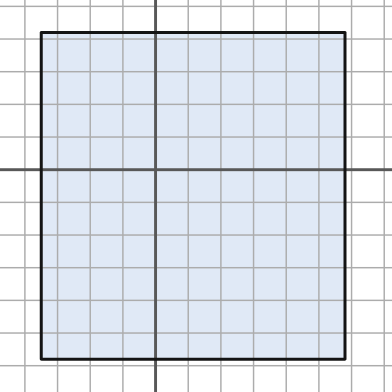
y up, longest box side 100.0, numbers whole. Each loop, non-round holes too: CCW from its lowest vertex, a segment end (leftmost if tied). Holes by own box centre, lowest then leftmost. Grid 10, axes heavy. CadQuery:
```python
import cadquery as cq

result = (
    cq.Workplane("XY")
    .moveTo(-35.0, -58.0)
    .lineTo(58.0, -58.0)
    .lineTo(58.0, 42.0)
    .lineTo(-35.0, 42.0)
    .close()
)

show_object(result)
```